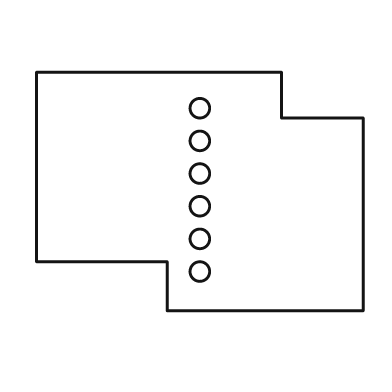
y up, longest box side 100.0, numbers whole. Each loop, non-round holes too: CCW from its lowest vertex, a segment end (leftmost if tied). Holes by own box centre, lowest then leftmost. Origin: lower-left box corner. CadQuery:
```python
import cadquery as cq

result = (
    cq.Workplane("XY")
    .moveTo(40.0, 0.0)
    .lineTo(100.0, 0.0)
    .lineTo(100.0, 59.0)
    .lineTo(75.0, 59.0)
    .lineTo(75.0, 73.0)
    .lineTo(0.0, 73.0)
    .lineTo(0.0, 15.0)
    .lineTo(40.0, 15.0)
    .close()
    .moveTo(50.0, 12.0)
    .circle(3.0)
    .moveTo(50.0, 22.0)
    .circle(3.0)
    .moveTo(50.0, 32.0)
    .circle(3.0)
    .moveTo(50.0, 42.0)
    .circle(3.0)
    .moveTo(50.0, 52.0)
    .circle(3.0)
    .moveTo(50.0, 62.0)
    .circle(3.0)
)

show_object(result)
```